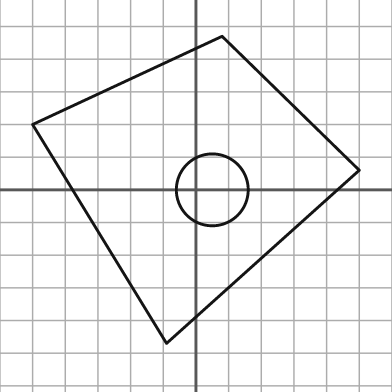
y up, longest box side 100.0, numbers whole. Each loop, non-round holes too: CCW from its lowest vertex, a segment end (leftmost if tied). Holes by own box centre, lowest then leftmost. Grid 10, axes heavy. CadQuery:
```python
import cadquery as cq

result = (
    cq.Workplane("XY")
    .moveTo(-9.0, -47.0)
    .lineTo(50.0, 6.0)
    .lineTo(8.0, 47.0)
    .lineTo(-50.0, 20.0)
    .close()
    .moveTo(5.0, 0.0)
    .circle(11.0)
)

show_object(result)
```